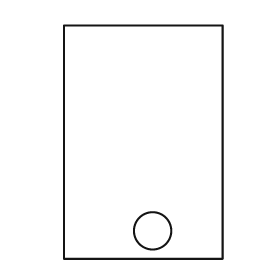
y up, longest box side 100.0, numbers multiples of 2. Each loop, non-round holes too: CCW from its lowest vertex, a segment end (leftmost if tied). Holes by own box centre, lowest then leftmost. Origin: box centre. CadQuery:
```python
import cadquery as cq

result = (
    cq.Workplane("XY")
    .moveTo(-34.0, -50.0)
    .lineTo(34.0, -50.0)
    .lineTo(34.0, 50.0)
    .lineTo(-34.0, 50.0)
    .close()
    .moveTo(4.0, -38.0)
    .circle(8.0)
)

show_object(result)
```